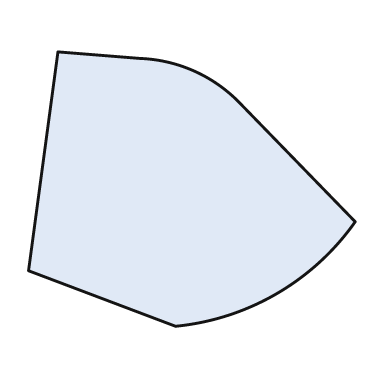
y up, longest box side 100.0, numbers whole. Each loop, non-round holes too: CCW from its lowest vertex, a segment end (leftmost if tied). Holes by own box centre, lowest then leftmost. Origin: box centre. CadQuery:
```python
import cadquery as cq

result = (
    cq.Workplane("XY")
    .moveTo(-5.0, -42.0)
    .threePointArc((26.0, -32.0), (50.0, -10.0))
    .lineTo(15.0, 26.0)
    .threePointArc((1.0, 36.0), (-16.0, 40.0))
    .lineTo(-41.0, 42.0)
    .lineTo(-50.0, -25.0)
    .close()
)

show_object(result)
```